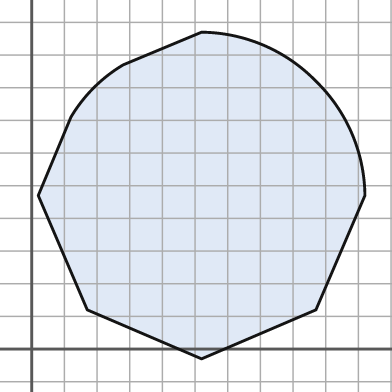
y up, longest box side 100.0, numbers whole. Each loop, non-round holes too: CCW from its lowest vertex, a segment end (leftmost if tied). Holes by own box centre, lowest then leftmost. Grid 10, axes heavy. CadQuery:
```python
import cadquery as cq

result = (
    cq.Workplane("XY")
    .moveTo(52.0, -3.0)
    .lineTo(87.0, 12.0)
    .lineTo(102.0, 47.0)
    .threePointArc((98.0, 66.0), (87.0, 82.0))
    .threePointArc((71.0, 93.0), (52.0, 97.0))
    .lineTo(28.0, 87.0)
    .threePointArc((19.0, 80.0), (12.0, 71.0))
    .lineTo(2.0, 47.0)
    .lineTo(17.0, 12.0)
    .close()
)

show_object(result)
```